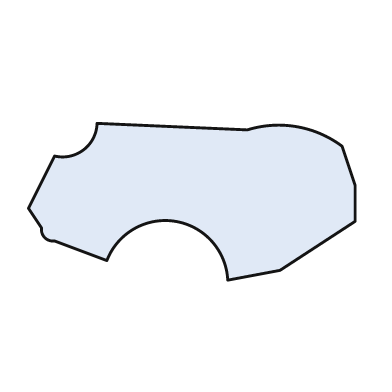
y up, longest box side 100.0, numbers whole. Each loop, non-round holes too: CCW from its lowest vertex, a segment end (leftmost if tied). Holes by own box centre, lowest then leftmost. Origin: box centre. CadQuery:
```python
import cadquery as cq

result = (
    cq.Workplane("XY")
    .moveTo(11.0, -24.0)
    .lineTo(27.0, -21.0)
    .lineTo(50.0, -6.0)
    .lineTo(50.0, 5.0)
    .lineTo(46.0, 17.0)
    .threePointArc((32.0, 23.0), (17.0, 22.0))
    .lineTo(-29.0, 24.0)
    .threePointArc((-33.0, 16.0), (-42.0, 14.0))
    .lineTo(-50.0, -2.0)
    .lineTo(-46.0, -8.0)
    .threePointArc((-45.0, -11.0), (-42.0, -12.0))
    .lineTo(-26.0, -18.0)
    .threePointArc((-5.0, -6.0), (11.0, -24.0))
    .close()
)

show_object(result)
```